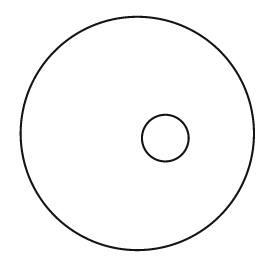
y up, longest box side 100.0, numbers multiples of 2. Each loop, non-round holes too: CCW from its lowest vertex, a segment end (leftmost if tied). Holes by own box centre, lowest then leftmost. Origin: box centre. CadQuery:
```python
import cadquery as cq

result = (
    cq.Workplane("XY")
    .moveTo(0.0, 0.0)
    .circle(50.0)
    .moveTo(12.0, -2.0)
    .circle(10.0)
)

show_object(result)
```